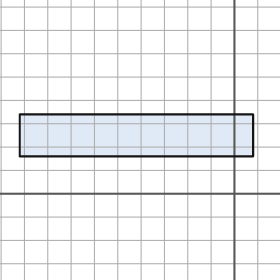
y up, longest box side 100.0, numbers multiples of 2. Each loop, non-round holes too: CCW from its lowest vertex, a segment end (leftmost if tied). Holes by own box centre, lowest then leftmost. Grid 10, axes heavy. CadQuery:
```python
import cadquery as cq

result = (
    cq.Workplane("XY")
    .moveTo(-92.0, 16.0)
    .lineTo(8.0, 16.0)
    .lineTo(8.0, 34.0)
    .lineTo(-92.0, 34.0)
    .close()
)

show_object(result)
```